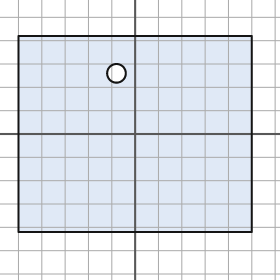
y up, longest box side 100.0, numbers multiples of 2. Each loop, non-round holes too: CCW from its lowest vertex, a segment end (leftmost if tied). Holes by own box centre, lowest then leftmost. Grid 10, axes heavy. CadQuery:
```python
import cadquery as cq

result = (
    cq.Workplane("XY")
    .moveTo(-50.0, -42.0)
    .lineTo(50.0, -42.0)
    .lineTo(50.0, 42.0)
    .lineTo(-50.0, 42.0)
    .close()
    .moveTo(-8.0, 26.0)
    .circle(4.0)
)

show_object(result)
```